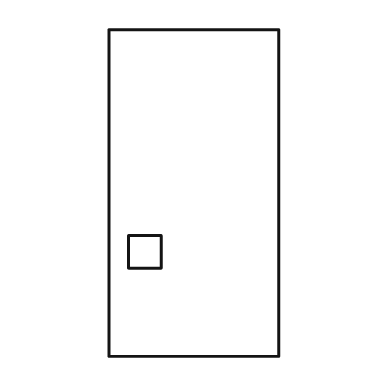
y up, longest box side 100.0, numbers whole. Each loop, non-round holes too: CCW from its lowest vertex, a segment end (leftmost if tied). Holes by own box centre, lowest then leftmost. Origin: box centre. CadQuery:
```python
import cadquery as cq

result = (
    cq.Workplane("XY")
    .moveTo(-26.0, -50.0)
    .lineTo(26.0, -50.0)
    .lineTo(26.0, 50.0)
    .lineTo(-26.0, 50.0)
    .close()
    .moveTo(-20.0, -23.0)
    .lineTo(-10.0, -23.0)
    .lineTo(-10.0, -13.0)
    .lineTo(-20.0, -13.0)
    .close()
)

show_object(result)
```